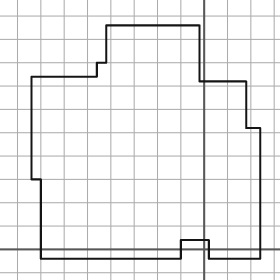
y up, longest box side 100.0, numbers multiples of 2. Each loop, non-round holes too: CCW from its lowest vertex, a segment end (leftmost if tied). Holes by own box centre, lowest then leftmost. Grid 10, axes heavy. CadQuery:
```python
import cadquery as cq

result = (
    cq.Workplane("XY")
    .moveTo(-70.0, -4.0)
    .lineTo(-10.0, -4.0)
    .lineTo(-10.0, 4.0)
    .lineTo(2.0, 4.0)
    .lineTo(2.0, -4.0)
    .lineTo(24.0, -4.0)
    .lineTo(24.0, 52.0)
    .lineTo(18.0, 52.0)
    .lineTo(18.0, 72.0)
    .lineTo(-2.0, 72.0)
    .lineTo(-2.0, 96.0)
    .lineTo(-42.0, 96.0)
    .lineTo(-42.0, 80.0)
    .lineTo(-46.0, 80.0)
    .lineTo(-46.0, 74.0)
    .lineTo(-74.0, 74.0)
    .lineTo(-74.0, 30.0)
    .lineTo(-70.0, 30.0)
    .close()
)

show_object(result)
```